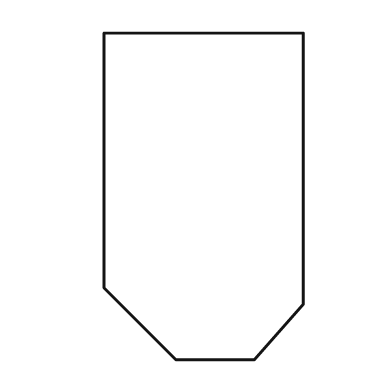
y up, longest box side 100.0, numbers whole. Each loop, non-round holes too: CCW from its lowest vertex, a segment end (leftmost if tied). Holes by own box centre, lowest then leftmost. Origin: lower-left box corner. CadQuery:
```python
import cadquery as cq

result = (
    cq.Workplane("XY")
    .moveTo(22.0, 0.0)
    .lineTo(46.0, 0.0)
    .lineTo(61.0, 17.0)
    .lineTo(61.0, 100.0)
    .lineTo(0.0, 100.0)
    .lineTo(0.0, 22.0)
    .close()
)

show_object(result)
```